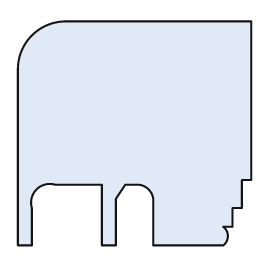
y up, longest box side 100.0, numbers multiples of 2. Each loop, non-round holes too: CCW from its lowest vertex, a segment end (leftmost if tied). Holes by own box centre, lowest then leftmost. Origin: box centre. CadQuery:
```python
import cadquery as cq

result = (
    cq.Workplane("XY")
    .moveTo(-50.0, -48.0)
    .lineTo(-44.0, -48.0)
    .lineTo(-44.0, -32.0)
    .threePointArc((-42.0, -24.0), (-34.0, -22.0))
    .lineTo(-14.0, -22.0)
    .lineTo(-14.0, -48.0)
    .lineTo(-8.0, -48.0)
    .lineTo(-8.0, -28.0)
    .lineTo(-4.0, -22.0)
    .lineTo(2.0, -22.0)
    .threePointArc((6.0, -24.0), (8.0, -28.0))
    .lineTo(8.0, -48.0)
    .lineTo(38.0, -48.0)
    .threePointArc((40.0, -44.0), (38.0, -40.0))
    .lineTo(42.0, -40.0)
    .lineTo(42.0, -32.0)
    .lineTo(46.0, -32.0)
    .lineTo(46.0, -20.0)
    .lineTo(50.0, -20.0)
    .lineTo(50.0, 48.0)
    .lineTo(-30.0, 48.0)
    .threePointArc((-44.0, 42.0), (-50.0, 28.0))
    .close()
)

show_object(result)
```